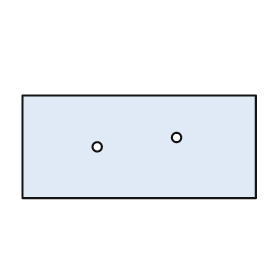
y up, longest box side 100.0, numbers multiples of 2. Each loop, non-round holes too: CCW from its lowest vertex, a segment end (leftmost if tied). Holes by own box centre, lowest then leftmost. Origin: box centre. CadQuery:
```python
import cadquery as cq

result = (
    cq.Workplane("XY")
    .moveTo(-50.0, -22.0)
    .lineTo(50.0, -22.0)
    .lineTo(50.0, 22.0)
    .lineTo(-50.0, 22.0)
    .close()
    .moveTo(-18.0, 0.0)
    .circle(2.0)
    .moveTo(16.0, 4.0)
    .circle(2.0)
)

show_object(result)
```